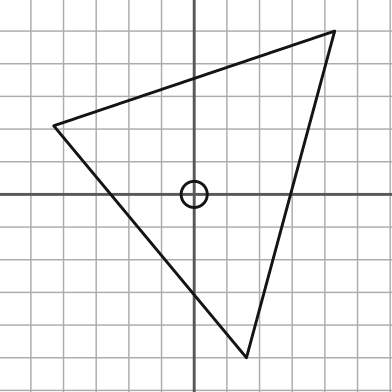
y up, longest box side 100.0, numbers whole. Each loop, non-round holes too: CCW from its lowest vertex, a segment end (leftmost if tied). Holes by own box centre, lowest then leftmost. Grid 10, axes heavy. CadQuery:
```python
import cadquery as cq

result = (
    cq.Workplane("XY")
    .moveTo(16.0, -50.0)
    .lineTo(43.0, 50.0)
    .lineTo(-43.0, 21.0)
    .close()
    .moveTo(0.0, 0.0)
    .circle(4.0)
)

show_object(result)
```